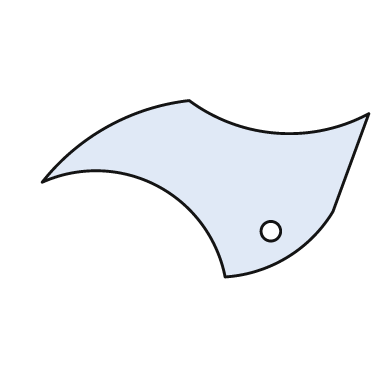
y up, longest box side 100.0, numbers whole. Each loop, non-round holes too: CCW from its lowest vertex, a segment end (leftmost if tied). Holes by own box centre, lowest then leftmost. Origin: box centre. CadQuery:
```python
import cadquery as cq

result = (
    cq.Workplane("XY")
    .moveTo(6.0, -27.0)
    .threePointArc((25.0, -21.0), (39.0, -7.0))
    .lineTo(50.0, 23.0)
    .threePointArc((22.0, 17.0), (-5.0, 27.0))
    .threePointArc((-30.0, 19.0), (-50.0, 2.0))
    .threePointArc((-15.0, 1.0), (6.0, -27.0))
    .close()
    .moveTo(20.0, -13.0)
    .circle(3.0)
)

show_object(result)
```